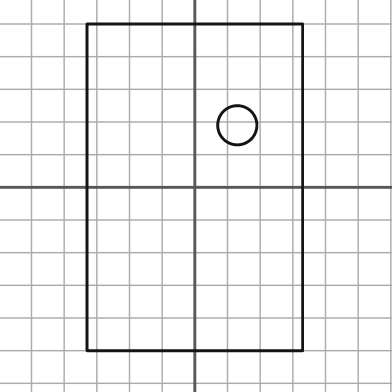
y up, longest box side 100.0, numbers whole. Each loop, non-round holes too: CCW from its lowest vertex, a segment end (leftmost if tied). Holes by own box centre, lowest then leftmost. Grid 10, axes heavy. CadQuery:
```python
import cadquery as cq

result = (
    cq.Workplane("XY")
    .moveTo(-33.0, -50.0)
    .lineTo(33.0, -50.0)
    .lineTo(33.0, 50.0)
    .lineTo(-33.0, 50.0)
    .close()
    .moveTo(13.0, 19.0)
    .circle(6.0)
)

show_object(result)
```